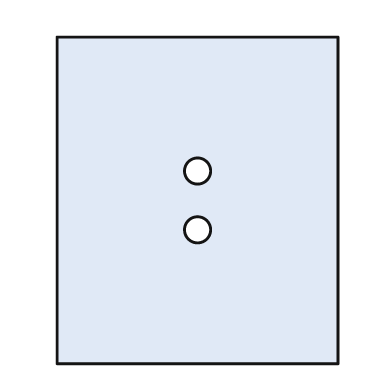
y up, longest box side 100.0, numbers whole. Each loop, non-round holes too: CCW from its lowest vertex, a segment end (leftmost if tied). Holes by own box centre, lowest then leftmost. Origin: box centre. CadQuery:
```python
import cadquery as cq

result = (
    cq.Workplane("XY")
    .moveTo(-43.0, -50.0)
    .lineTo(43.0, -50.0)
    .lineTo(43.0, 50.0)
    .lineTo(-43.0, 50.0)
    .close()
    .moveTo(0.0, -9.0)
    .circle(4.0)
    .moveTo(0.0, 9.0)
    .circle(4.0)
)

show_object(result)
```